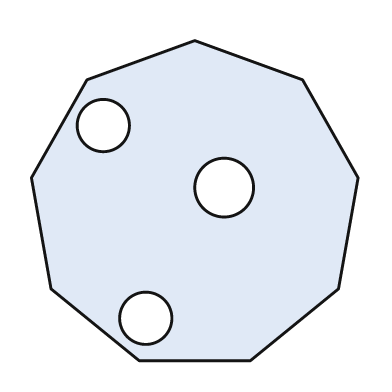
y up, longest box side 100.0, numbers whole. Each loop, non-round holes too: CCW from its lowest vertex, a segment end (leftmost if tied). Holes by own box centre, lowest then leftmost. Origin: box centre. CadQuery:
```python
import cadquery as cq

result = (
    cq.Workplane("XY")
    .moveTo(-17.0, -49.0)
    .lineTo(17.0, -49.0)
    .lineTo(44.0, -27.0)
    .lineTo(50.0, 7.0)
    .lineTo(33.0, 37.0)
    .lineTo(0.0, 49.0)
    .lineTo(-33.0, 37.0)
    .lineTo(-50.0, 7.0)
    .lineTo(-44.0, -27.0)
    .close()
    .moveTo(-15.0, -36.0)
    .circle(8.0)
    .moveTo(9.0, 4.0)
    .circle(9.0)
    .moveTo(-28.0, 23.0)
    .circle(8.0)
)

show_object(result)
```